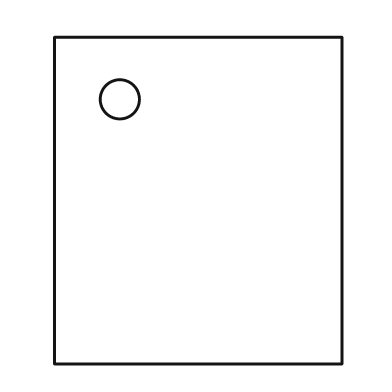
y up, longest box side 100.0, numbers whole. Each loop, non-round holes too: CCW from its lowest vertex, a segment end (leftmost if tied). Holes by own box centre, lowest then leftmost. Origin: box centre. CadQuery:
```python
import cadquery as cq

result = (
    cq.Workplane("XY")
    .moveTo(-44.0, -50.0)
    .lineTo(44.0, -50.0)
    .lineTo(44.0, 50.0)
    .lineTo(-44.0, 50.0)
    .close()
    .moveTo(-24.0, 31.0)
    .circle(6.0)
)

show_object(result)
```